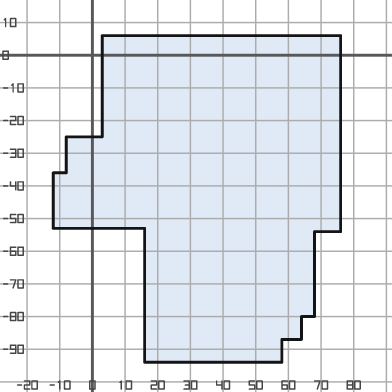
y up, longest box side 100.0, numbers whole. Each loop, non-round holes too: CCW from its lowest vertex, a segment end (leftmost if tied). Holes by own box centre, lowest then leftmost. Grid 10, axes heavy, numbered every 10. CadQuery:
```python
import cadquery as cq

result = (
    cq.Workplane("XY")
    .moveTo(16.0, -94.0)
    .lineTo(58.0, -94.0)
    .lineTo(58.0, -87.0)
    .lineTo(64.0, -87.0)
    .lineTo(64.0, -80.0)
    .lineTo(68.0, -80.0)
    .lineTo(68.0, -54.0)
    .lineTo(76.0, -54.0)
    .lineTo(76.0, 6.0)
    .lineTo(3.0, 6.0)
    .lineTo(3.0, -25.0)
    .lineTo(-8.0, -25.0)
    .lineTo(-8.0, -36.0)
    .lineTo(-12.0, -36.0)
    .lineTo(-12.0, -53.0)
    .lineTo(16.0, -53.0)
    .close()
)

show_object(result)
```